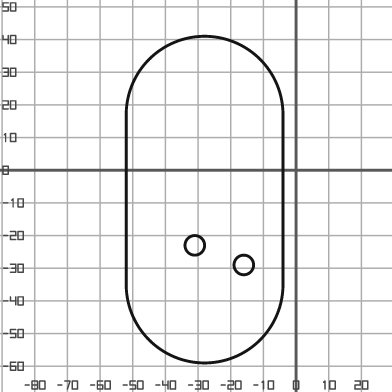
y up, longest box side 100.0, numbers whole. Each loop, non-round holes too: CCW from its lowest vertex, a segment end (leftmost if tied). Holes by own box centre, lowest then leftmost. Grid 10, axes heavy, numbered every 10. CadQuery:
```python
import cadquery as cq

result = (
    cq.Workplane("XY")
    .moveTo(-52.0, -35.0)
    .threePointArc((-28.0, -59.0), (-4.0, -35.0))
    .lineTo(-4.0, 17.0)
    .threePointArc((-28.0, 41.0), (-52.0, 17.0))
    .close()
    .moveTo(-16.0, -29.0)
    .circle(3.0)
    .moveTo(-31.0, -23.0)
    .circle(3.0)
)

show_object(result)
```